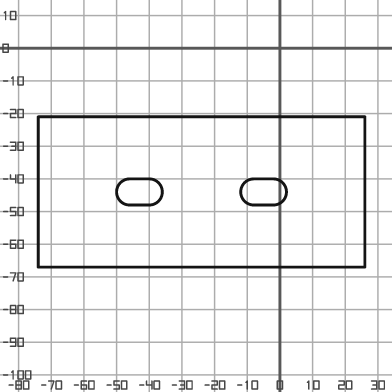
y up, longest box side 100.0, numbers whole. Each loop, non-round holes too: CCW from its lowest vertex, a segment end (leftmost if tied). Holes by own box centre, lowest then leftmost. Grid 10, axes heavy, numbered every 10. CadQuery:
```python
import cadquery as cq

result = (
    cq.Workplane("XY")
    .moveTo(-74.0, -67.0)
    .lineTo(26.0, -67.0)
    .lineTo(26.0, -21.0)
    .lineTo(-74.0, -21.0)
    .close()
    .moveTo(-46.0, -48.0)
    .lineTo(-40.0, -48.0)
    .threePointArc((-36.0, -44.0), (-40.0, -40.0))
    .lineTo(-46.0, -40.0)
    .threePointArc((-50.0, -44.0), (-46.0, -48.0))
    .close()
    .moveTo(-8.0, -48.0)
    .lineTo(-2.0, -48.0)
    .threePointArc((2.0, -44.0), (-2.0, -40.0))
    .lineTo(-8.0, -40.0)
    .threePointArc((-12.0, -44.0), (-8.0, -48.0))
    .close()
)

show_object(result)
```